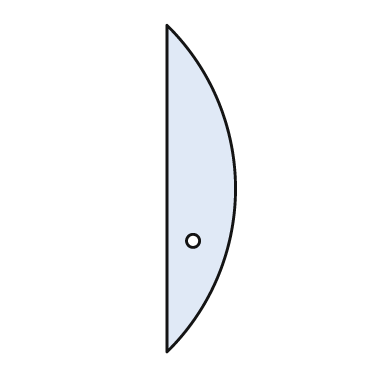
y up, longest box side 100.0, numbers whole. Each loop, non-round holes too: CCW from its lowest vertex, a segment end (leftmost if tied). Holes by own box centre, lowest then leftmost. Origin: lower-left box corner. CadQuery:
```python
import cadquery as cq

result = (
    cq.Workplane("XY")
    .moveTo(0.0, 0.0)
    .threePointArc((21.0, 50.0), (0.0, 100.0))
    .close()
    .moveTo(8.0, 34.0)
    .circle(2.0)
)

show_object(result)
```